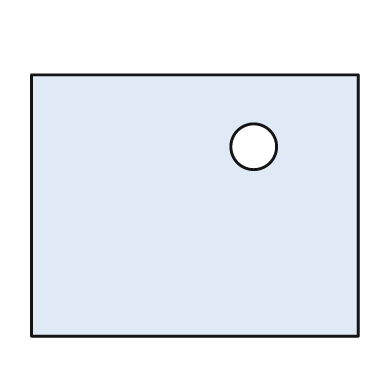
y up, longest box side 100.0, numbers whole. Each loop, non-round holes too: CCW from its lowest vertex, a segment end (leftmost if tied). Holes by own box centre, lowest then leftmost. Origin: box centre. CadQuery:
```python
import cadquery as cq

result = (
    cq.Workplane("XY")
    .moveTo(-50.0, -40.0)
    .lineTo(50.0, -40.0)
    .lineTo(50.0, 40.0)
    .lineTo(-50.0, 40.0)
    .close()
    .moveTo(18.0, 18.0)
    .circle(7.0)
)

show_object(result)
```